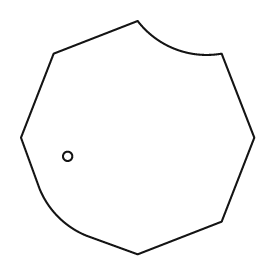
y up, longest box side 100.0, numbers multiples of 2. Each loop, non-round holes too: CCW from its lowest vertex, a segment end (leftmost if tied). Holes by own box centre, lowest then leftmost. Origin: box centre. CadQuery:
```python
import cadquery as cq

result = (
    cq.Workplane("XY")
    .moveTo(0.0, -50.0)
    .lineTo(36.0, -36.0)
    .lineTo(50.0, 0.0)
    .lineTo(36.0, 36.0)
    .threePointArc((16.0, 38.0), (0.0, 50.0))
    .lineTo(-36.0, 36.0)
    .lineTo(-50.0, 0.0)
    .lineTo(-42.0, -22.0)
    .threePointArc((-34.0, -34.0), (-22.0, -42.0))
    .close()
    .moveTo(-30.0, -8.0)
    .circle(2.0)
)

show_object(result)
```